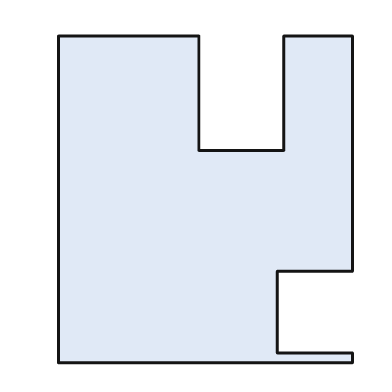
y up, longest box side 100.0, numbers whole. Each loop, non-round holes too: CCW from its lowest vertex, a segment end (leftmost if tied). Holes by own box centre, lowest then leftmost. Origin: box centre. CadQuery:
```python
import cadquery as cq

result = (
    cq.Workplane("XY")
    .moveTo(-45.0, -50.0)
    .lineTo(45.0, -50.0)
    .lineTo(45.0, -47.0)
    .lineTo(22.0, -47.0)
    .lineTo(22.0, -22.0)
    .lineTo(45.0, -22.0)
    .lineTo(45.0, 50.0)
    .lineTo(24.0, 50.0)
    .lineTo(24.0, 15.0)
    .lineTo(-2.0, 15.0)
    .lineTo(-2.0, 50.0)
    .lineTo(-45.0, 50.0)
    .close()
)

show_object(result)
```